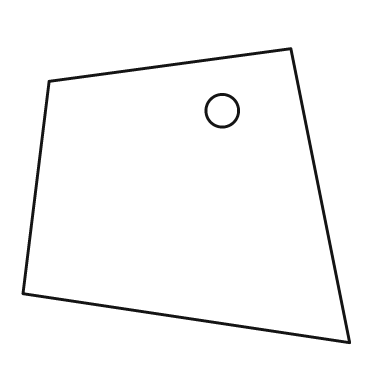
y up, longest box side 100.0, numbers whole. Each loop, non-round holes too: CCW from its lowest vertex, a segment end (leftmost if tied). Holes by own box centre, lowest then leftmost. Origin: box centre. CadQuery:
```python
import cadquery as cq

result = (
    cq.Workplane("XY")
    .moveTo(50.0, -45.0)
    .lineTo(32.0, 45.0)
    .lineTo(-42.0, 35.0)
    .lineTo(-50.0, -30.0)
    .close()
    .moveTo(11.0, 26.0)
    .circle(5.0)
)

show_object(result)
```